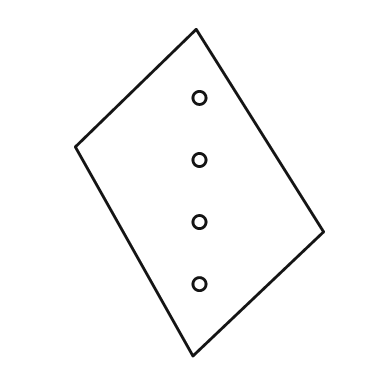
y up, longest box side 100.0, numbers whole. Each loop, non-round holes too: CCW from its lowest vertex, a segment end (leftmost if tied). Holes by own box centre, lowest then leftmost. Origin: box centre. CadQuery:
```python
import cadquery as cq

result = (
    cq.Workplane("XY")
    .moveTo(-2.0, -50.0)
    .lineTo(38.0, -12.0)
    .lineTo(-1.0, 50.0)
    .lineTo(-38.0, 14.0)
    .close()
    .moveTo(0.0, -28.0)
    .circle(2.0)
    .moveTo(0.0, -9.0)
    .circle(2.0)
    .moveTo(0.0, 10.0)
    .circle(2.0)
    .moveTo(0.0, 29.0)
    .circle(2.0)
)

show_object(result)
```